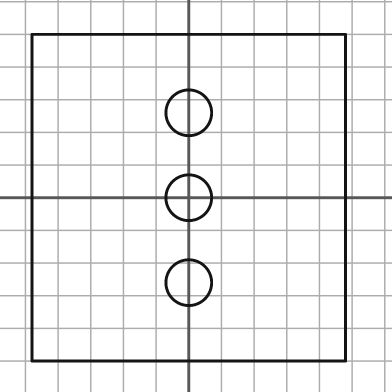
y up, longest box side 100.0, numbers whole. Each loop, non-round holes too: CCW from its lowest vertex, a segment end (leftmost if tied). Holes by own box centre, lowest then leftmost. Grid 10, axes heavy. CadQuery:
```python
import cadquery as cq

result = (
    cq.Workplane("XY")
    .moveTo(-48.0, -50.0)
    .lineTo(48.0, -50.0)
    .lineTo(48.0, 50.0)
    .lineTo(-48.0, 50.0)
    .close()
    .moveTo(0.0, -26.0)
    .circle(7.0)
    .moveTo(0.0, 0.0)
    .circle(7.0)
    .moveTo(0.0, 26.0)
    .circle(7.0)
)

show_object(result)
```